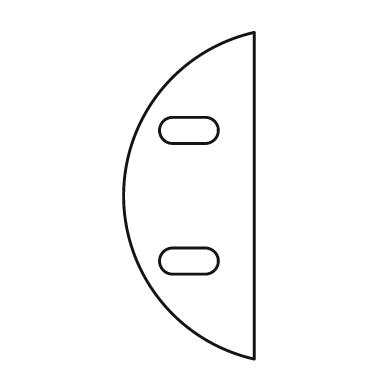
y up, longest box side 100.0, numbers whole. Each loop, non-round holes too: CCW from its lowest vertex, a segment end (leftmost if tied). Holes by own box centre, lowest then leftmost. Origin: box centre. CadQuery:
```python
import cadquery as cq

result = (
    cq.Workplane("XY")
    .moveTo(20.0, -50.0)
    .lineTo(20.0, 50.0)
    .threePointArc((-20.0, 0.0), (20.0, -50.0))
    .close()
    .moveTo(-5.0, -24.0)
    .lineTo(5.0, -24.0)
    .threePointArc((9.0, -20.0), (5.0, -16.0))
    .lineTo(-5.0, -16.0)
    .threePointArc((-9.0, -20.0), (-5.0, -24.0))
    .close()
    .moveTo(-5.0, 16.0)
    .lineTo(5.0, 16.0)
    .threePointArc((9.0, 20.0), (5.0, 24.0))
    .lineTo(-5.0, 24.0)
    .threePointArc((-9.0, 20.0), (-5.0, 16.0))
    .close()
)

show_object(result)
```